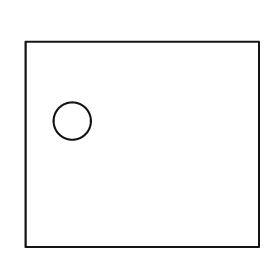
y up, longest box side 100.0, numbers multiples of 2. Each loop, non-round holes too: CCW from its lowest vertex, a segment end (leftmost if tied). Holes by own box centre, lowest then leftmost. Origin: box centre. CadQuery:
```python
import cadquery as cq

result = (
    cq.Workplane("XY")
    .moveTo(-50.0, -44.0)
    .lineTo(50.0, -44.0)
    .lineTo(50.0, 44.0)
    .lineTo(-50.0, 44.0)
    .close()
    .moveTo(-30.0, 10.0)
    .circle(8.0)
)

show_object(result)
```